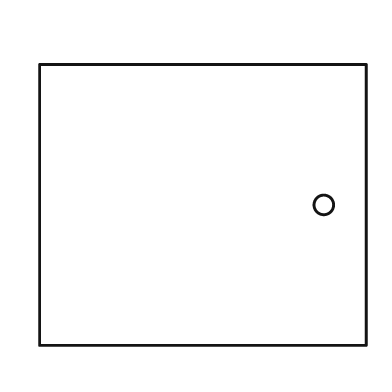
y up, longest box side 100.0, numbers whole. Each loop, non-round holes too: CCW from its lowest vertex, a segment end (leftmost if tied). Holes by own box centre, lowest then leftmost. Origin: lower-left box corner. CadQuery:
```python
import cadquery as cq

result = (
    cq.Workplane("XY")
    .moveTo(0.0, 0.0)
    .lineTo(100.0, 0.0)
    .lineTo(100.0, 86.0)
    .lineTo(0.0, 86.0)
    .close()
    .moveTo(87.0, 43.0)
    .circle(3.0)
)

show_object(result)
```